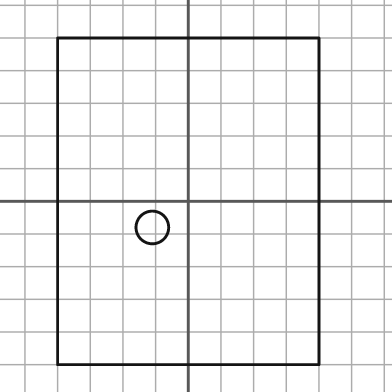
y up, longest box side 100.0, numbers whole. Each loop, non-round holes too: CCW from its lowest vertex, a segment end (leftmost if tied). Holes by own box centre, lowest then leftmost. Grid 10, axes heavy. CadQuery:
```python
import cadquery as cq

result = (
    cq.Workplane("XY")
    .moveTo(-40.0, -50.0)
    .lineTo(40.0, -50.0)
    .lineTo(40.0, 50.0)
    .lineTo(-40.0, 50.0)
    .close()
    .moveTo(-11.0, -8.0)
    .circle(5.0)
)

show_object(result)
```